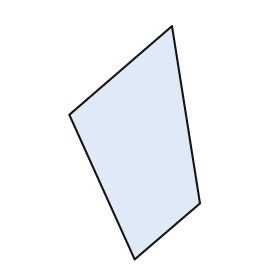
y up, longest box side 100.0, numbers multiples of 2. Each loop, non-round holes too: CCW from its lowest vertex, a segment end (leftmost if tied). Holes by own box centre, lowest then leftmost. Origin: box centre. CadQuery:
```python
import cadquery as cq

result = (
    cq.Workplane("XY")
    .moveTo(0.0, -50.0)
    .lineTo(28.0, -26.0)
    .lineTo(16.0, 50.0)
    .lineTo(-28.0, 12.0)
    .close()
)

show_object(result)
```